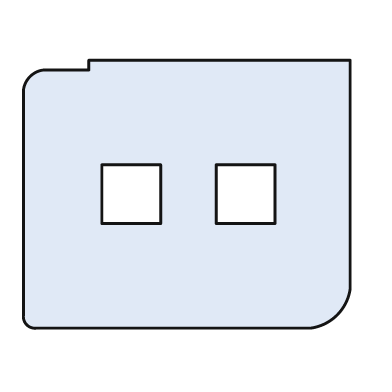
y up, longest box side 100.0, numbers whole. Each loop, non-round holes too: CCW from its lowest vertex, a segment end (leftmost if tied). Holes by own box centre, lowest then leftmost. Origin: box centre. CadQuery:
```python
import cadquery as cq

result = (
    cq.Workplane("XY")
    .moveTo(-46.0, -41.0)
    .lineTo(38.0, -41.0)
    .threePointArc((46.0, -37.0), (50.0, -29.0))
    .lineTo(50.0, 41.0)
    .lineTo(-30.0, 41.0)
    .lineTo(-30.0, 38.0)
    .lineTo(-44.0, 38.0)
    .threePointArc((-48.0, 36.0), (-50.0, 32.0))
    .lineTo(-50.0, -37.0)
    .threePointArc((-49.0, -40.0), (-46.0, -41.0))
    .close()
    .moveTo(-26.0, -9.0)
    .lineTo(-8.0, -9.0)
    .lineTo(-8.0, 9.0)
    .lineTo(-26.0, 9.0)
    .close()
    .moveTo(9.0, -9.0)
    .lineTo(27.0, -9.0)
    .lineTo(27.0, 9.0)
    .lineTo(9.0, 9.0)
    .close()
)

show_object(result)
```